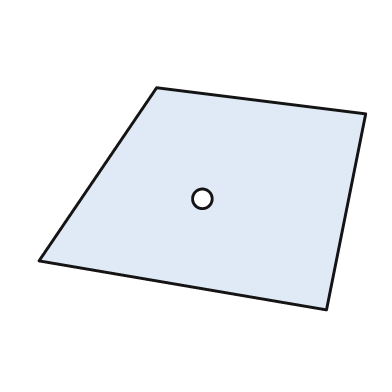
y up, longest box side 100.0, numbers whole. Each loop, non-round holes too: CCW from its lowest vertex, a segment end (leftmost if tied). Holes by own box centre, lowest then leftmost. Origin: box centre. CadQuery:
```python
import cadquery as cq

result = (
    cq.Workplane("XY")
    .moveTo(38.0, -34.0)
    .lineTo(50.0, 26.0)
    .lineTo(-14.0, 34.0)
    .lineTo(-50.0, -19.0)
    .close()
    .moveTo(0.0, 0.0)
    .circle(3.0)
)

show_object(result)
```